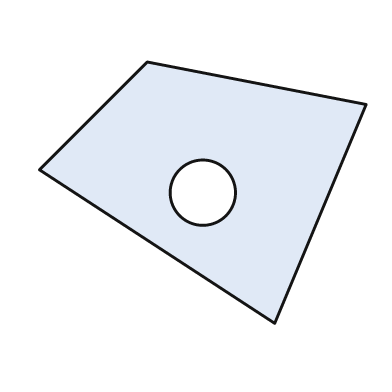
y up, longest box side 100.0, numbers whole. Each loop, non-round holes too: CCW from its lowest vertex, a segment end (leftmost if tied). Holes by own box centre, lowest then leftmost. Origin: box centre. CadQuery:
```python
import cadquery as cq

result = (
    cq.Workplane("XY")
    .moveTo(22.0, -40.0)
    .lineTo(50.0, 27.0)
    .lineTo(-17.0, 40.0)
    .lineTo(-50.0, 7.0)
    .close()
    .moveTo(0.0, 0.0)
    .circle(10.0)
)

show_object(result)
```